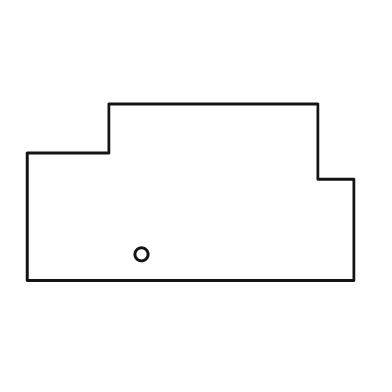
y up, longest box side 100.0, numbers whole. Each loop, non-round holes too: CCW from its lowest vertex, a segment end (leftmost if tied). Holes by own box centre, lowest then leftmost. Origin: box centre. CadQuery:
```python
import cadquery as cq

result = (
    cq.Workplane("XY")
    .moveTo(-50.0, -27.0)
    .lineTo(50.0, -27.0)
    .lineTo(50.0, 4.0)
    .lineTo(39.0, 4.0)
    .lineTo(39.0, 27.0)
    .lineTo(-25.0, 27.0)
    .lineTo(-25.0, 12.0)
    .lineTo(-50.0, 12.0)
    .close()
    .moveTo(-15.0, -19.0)
    .circle(2.0)
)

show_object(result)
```